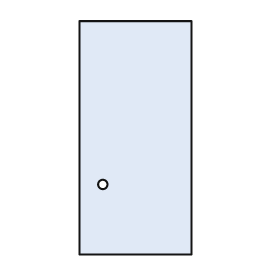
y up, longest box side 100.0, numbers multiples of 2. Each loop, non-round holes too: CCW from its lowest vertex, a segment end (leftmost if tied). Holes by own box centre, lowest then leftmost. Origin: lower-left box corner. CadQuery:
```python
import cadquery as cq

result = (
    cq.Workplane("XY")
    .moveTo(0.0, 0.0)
    .lineTo(48.0, 0.0)
    .lineTo(48.0, 100.0)
    .lineTo(0.0, 100.0)
    .close()
    .moveTo(10.0, 30.0)
    .circle(2.0)
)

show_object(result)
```